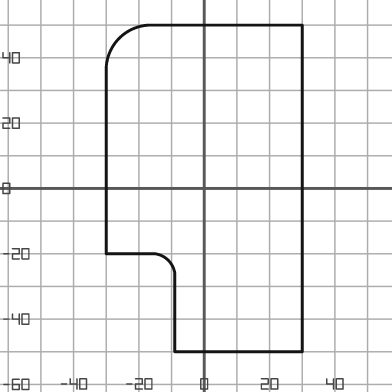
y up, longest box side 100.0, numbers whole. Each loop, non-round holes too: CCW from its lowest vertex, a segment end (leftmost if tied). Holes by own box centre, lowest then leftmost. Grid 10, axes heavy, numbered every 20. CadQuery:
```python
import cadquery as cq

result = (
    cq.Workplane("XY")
    .moveTo(-9.0, -50.0)
    .lineTo(30.0, -50.0)
    .lineTo(30.0, 50.0)
    .lineTo(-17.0, 50.0)
    .threePointArc((-26.0, 46.0), (-30.0, 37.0))
    .lineTo(-30.0, -20.0)
    .lineTo(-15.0, -20.0)
    .threePointArc((-11.0, -22.0), (-9.0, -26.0))
    .close()
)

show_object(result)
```